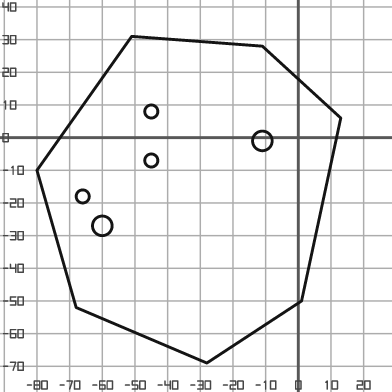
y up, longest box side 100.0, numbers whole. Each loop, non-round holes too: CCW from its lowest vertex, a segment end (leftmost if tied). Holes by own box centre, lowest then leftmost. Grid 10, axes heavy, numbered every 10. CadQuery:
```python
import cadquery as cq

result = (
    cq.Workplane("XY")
    .moveTo(-28.0, -69.0)
    .lineTo(1.0, -50.0)
    .lineTo(13.0, 6.0)
    .lineTo(-11.0, 28.0)
    .lineTo(-51.0, 31.0)
    .lineTo(-80.0, -10.0)
    .lineTo(-68.0, -52.0)
    .close()
    .moveTo(-60.0, -27.0)
    .circle(3.0)
    .moveTo(-66.0, -18.0)
    .circle(2.0)
    .moveTo(-45.0, -7.0)
    .circle(2.0)
    .moveTo(-11.0, -1.0)
    .circle(3.0)
    .moveTo(-45.0, 8.0)
    .circle(2.0)
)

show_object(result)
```